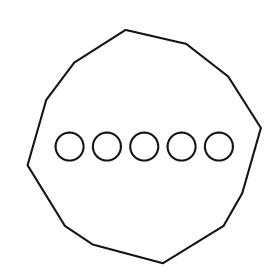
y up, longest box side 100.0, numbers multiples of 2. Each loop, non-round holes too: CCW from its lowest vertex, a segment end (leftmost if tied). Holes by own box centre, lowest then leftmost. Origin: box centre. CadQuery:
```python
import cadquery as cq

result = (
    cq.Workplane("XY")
    .moveTo(8.0, -50.0)
    .lineTo(34.0, -34.0)
    .lineTo(42.0, -20.0)
    .lineTo(50.0, 8.0)
    .lineTo(36.0, 30.0)
    .lineTo(18.0, 44.0)
    .lineTo(-8.0, 50.0)
    .lineTo(-30.0, 36.0)
    .lineTo(-42.0, 20.0)
    .lineTo(-50.0, -8.0)
    .lineTo(-34.0, -34.0)
    .lineTo(-22.0, -42.0)
    .close()
    .moveTo(-32.0, 0.0)
    .circle(6.0)
    .moveTo(-16.0, 0.0)
    .circle(6.0)
    .moveTo(0.0, 0.0)
    .circle(6.0)
    .moveTo(16.0, 0.0)
    .circle(6.0)
    .moveTo(32.0, 0.0)
    .circle(6.0)
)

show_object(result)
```